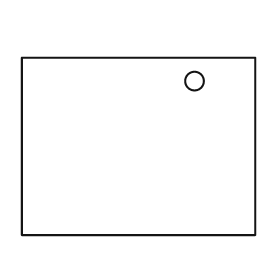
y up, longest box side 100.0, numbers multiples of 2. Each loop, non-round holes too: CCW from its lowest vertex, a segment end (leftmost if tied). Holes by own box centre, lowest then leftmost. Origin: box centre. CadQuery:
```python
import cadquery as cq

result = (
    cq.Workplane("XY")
    .moveTo(-50.0, -38.0)
    .lineTo(50.0, -38.0)
    .lineTo(50.0, 38.0)
    .lineTo(-50.0, 38.0)
    .close()
    .moveTo(24.0, 28.0)
    .circle(4.0)
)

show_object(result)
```